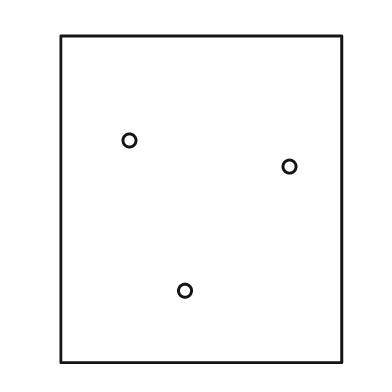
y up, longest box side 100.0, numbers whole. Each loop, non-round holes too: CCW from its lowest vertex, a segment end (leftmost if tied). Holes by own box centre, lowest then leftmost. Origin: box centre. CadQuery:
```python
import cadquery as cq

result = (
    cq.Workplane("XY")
    .moveTo(-43.0, -50.0)
    .lineTo(43.0, -50.0)
    .lineTo(43.0, 50.0)
    .lineTo(-43.0, 50.0)
    .close()
    .moveTo(-5.0, -28.0)
    .circle(2.0)
    .moveTo(27.0, 10.0)
    .circle(2.0)
    .moveTo(-22.0, 18.0)
    .circle(2.0)
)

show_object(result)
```